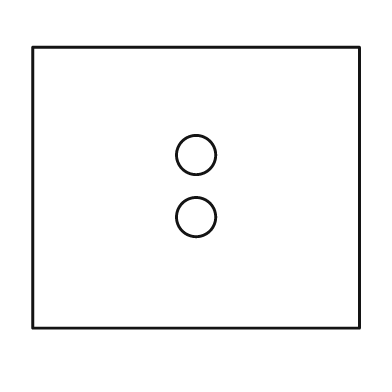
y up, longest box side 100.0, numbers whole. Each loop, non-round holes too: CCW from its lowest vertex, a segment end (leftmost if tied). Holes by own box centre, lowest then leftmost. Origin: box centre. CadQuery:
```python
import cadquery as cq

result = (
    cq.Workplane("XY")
    .moveTo(-50.0, -43.0)
    .lineTo(50.0, -43.0)
    .lineTo(50.0, 43.0)
    .lineTo(-50.0, 43.0)
    .close()
    .moveTo(0.0, -9.0)
    .circle(6.0)
    .moveTo(0.0, 10.0)
    .circle(6.0)
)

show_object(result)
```